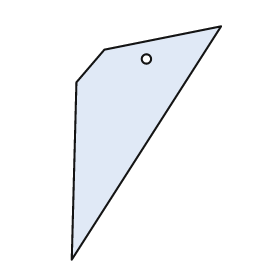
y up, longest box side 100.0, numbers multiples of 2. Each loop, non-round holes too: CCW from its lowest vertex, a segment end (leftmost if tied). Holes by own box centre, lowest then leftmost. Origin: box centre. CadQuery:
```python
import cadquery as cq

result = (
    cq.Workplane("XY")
    .moveTo(-32.0, -50.0)
    .lineTo(32.0, 50.0)
    .lineTo(-18.0, 40.0)
    .lineTo(-30.0, 26.0)
    .close()
    .moveTo(0.0, 36.0)
    .circle(2.0)
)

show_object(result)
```